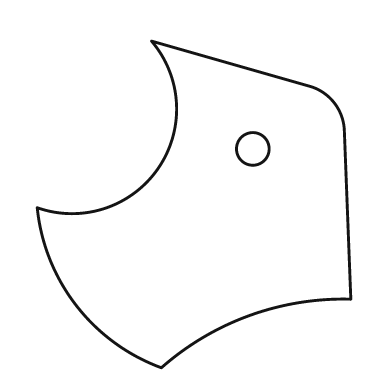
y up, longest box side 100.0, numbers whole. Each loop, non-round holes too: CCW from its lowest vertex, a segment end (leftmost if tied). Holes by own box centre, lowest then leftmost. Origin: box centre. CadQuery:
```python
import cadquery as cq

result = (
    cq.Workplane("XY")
    .moveTo(-10.0, -50.0)
    .threePointArc((17.0, -34.0), (48.0, -29.0))
    .lineTo(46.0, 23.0)
    .threePointArc((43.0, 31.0), (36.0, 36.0))
    .lineTo(-13.0, 50.0)
    .threePointArc((-11.0, 11.0), (-48.0, -1.0))
    .threePointArc((-36.0, -31.0), (-10.0, -50.0))
    .close()
    .moveTo(18.0, 17.0)
    .circle(5.0)
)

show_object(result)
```